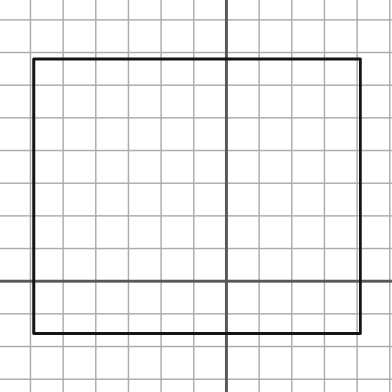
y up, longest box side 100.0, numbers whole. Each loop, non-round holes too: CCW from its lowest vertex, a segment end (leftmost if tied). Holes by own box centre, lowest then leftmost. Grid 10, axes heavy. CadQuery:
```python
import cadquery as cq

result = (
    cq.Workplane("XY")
    .moveTo(-59.0, -16.0)
    .lineTo(41.0, -16.0)
    .lineTo(41.0, 68.0)
    .lineTo(-59.0, 68.0)
    .close()
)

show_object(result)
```